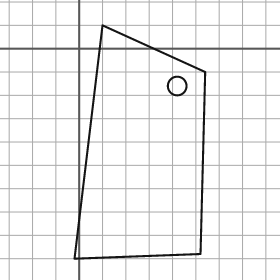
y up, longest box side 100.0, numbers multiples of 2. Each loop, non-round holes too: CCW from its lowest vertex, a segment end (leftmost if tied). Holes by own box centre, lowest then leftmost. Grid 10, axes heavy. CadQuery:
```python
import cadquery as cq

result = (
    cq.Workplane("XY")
    .moveTo(-2.0, -90.0)
    .lineTo(52.0, -88.0)
    .lineTo(54.0, -10.0)
    .lineTo(10.0, 10.0)
    .close()
    .moveTo(42.0, -16.0)
    .circle(4.0)
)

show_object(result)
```